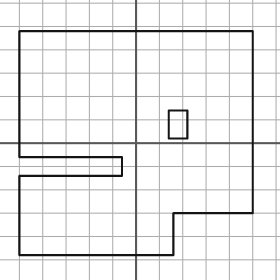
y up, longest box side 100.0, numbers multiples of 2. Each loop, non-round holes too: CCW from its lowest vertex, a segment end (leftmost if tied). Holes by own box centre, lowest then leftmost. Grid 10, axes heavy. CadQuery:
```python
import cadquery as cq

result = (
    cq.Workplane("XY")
    .moveTo(-50.0, -48.0)
    .lineTo(16.0, -48.0)
    .lineTo(16.0, -30.0)
    .lineTo(50.0, -30.0)
    .lineTo(50.0, 48.0)
    .lineTo(-50.0, 48.0)
    .lineTo(-50.0, -6.0)
    .lineTo(-6.0, -6.0)
    .lineTo(-6.0, -14.0)
    .lineTo(-50.0, -14.0)
    .close()
    .moveTo(14.0, 2.0)
    .lineTo(22.0, 2.0)
    .lineTo(22.0, 14.0)
    .lineTo(14.0, 14.0)
    .close()
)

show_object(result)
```